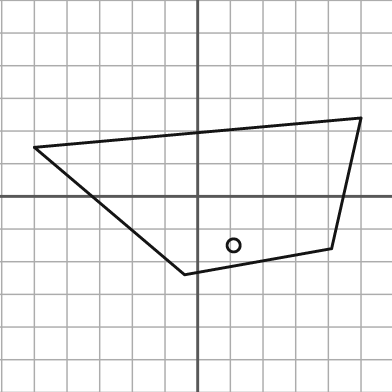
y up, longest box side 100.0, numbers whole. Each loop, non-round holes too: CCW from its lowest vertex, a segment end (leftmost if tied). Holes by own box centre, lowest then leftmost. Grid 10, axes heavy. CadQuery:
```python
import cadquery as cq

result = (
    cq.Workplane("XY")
    .moveTo(-4.0, -24.0)
    .lineTo(41.0, -16.0)
    .lineTo(50.0, 24.0)
    .lineTo(-50.0, 15.0)
    .close()
    .moveTo(11.0, -15.0)
    .circle(2.0)
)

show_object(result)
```